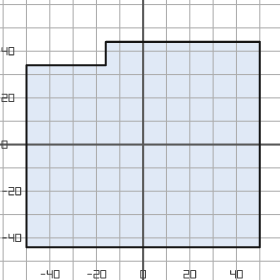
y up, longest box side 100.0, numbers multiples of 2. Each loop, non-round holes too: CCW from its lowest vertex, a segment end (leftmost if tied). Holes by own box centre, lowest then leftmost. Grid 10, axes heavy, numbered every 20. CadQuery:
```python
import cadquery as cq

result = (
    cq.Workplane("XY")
    .moveTo(-50.0, -44.0)
    .lineTo(50.0, -44.0)
    .lineTo(50.0, 44.0)
    .lineTo(-16.0, 44.0)
    .lineTo(-16.0, 34.0)
    .lineTo(-50.0, 34.0)
    .close()
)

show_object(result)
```